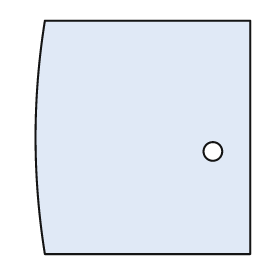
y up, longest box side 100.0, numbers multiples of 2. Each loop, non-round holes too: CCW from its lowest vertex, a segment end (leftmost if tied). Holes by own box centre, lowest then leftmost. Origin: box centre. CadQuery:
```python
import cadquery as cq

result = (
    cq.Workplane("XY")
    .moveTo(-42.0, -50.0)
    .lineTo(46.0, -50.0)
    .lineTo(46.0, 50.0)
    .lineTo(-42.0, 50.0)
    .threePointArc((-46.0, 0.0), (-42.0, -50.0))
    .close()
    .moveTo(30.0, -6.0)
    .circle(4.0)
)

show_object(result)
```